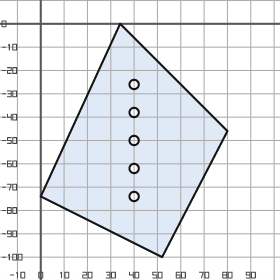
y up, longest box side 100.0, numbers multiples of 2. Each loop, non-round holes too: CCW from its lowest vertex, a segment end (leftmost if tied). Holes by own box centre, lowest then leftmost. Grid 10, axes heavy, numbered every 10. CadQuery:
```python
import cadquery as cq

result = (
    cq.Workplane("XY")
    .moveTo(52.0, -100.0)
    .lineTo(80.0, -46.0)
    .lineTo(34.0, 0.0)
    .lineTo(0.0, -74.0)
    .close()
    .moveTo(40.0, -74.0)
    .circle(2.0)
    .moveTo(40.0, -62.0)
    .circle(2.0)
    .moveTo(40.0, -50.0)
    .circle(2.0)
    .moveTo(40.0, -38.0)
    .circle(2.0)
    .moveTo(40.0, -26.0)
    .circle(2.0)
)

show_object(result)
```